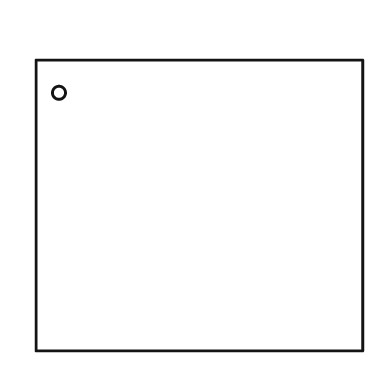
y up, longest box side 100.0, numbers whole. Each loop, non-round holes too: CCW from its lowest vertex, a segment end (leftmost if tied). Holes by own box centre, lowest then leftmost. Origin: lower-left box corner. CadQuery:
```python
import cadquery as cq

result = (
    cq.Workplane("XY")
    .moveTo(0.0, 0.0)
    .lineTo(100.0, 0.0)
    .lineTo(100.0, 89.0)
    .lineTo(0.0, 89.0)
    .close()
    .moveTo(7.0, 79.0)
    .circle(2.0)
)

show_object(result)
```